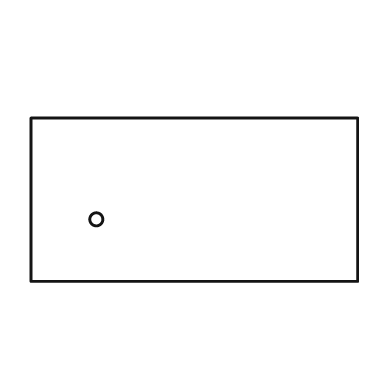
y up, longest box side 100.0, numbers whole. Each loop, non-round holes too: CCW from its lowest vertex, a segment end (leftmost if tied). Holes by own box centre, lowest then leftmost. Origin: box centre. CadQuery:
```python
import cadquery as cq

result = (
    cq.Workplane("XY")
    .moveTo(-50.0, -25.0)
    .lineTo(50.0, -25.0)
    .lineTo(50.0, 25.0)
    .lineTo(-50.0, 25.0)
    .close()
    .moveTo(-30.0, -6.0)
    .circle(2.0)
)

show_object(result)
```